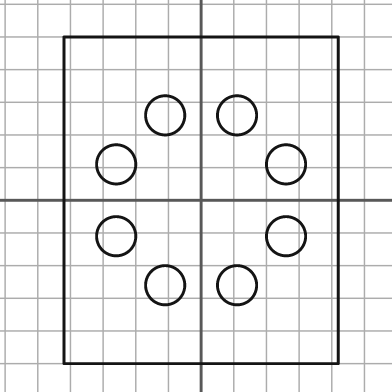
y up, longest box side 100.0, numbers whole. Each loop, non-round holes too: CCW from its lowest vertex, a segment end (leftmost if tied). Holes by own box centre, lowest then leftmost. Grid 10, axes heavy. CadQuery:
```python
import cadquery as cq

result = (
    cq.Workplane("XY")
    .moveTo(-42.0, -50.0)
    .lineTo(42.0, -50.0)
    .lineTo(42.0, 50.0)
    .lineTo(-42.0, 50.0)
    .close()
    .moveTo(-11.0, -26.0)
    .circle(6.0)
    .moveTo(11.0, -26.0)
    .circle(6.0)
    .moveTo(-26.0, -11.0)
    .circle(6.0)
    .moveTo(26.0, -11.0)
    .circle(6.0)
    .moveTo(-26.0, 11.0)
    .circle(6.0)
    .moveTo(26.0, 11.0)
    .circle(6.0)
    .moveTo(-11.0, 26.0)
    .circle(6.0)
    .moveTo(11.0, 26.0)
    .circle(6.0)
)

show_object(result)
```